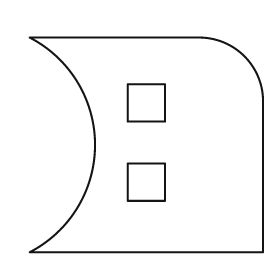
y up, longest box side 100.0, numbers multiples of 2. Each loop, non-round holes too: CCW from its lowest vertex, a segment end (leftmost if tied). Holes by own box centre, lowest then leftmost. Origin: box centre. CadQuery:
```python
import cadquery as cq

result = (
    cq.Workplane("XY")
    .moveTo(-50.0, -46.0)
    .lineTo(50.0, -46.0)
    .lineTo(50.0, 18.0)
    .threePointArc((42.0, 38.0), (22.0, 46.0))
    .lineTo(-50.0, 46.0)
    .threePointArc((-22.0, 0.0), (-50.0, -46.0))
    .close()
    .moveTo(-8.0, -24.0)
    .lineTo(8.0, -24.0)
    .lineTo(8.0, -8.0)
    .lineTo(-8.0, -8.0)
    .close()
    .moveTo(-8.0, 10.0)
    .lineTo(8.0, 10.0)
    .lineTo(8.0, 26.0)
    .lineTo(-8.0, 26.0)
    .close()
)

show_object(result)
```